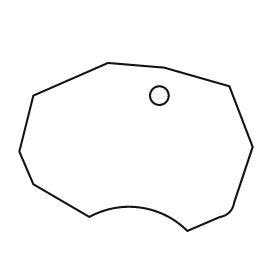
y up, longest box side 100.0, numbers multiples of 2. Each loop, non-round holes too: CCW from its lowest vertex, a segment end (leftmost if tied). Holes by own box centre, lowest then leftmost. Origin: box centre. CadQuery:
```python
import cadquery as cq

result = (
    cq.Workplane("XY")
    .moveTo(22.0, -36.0)
    .lineTo(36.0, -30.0)
    .threePointArc((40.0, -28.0), (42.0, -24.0))
    .lineTo(50.0, 0.0)
    .lineTo(40.0, 26.0)
    .lineTo(12.0, 34.0)
    .lineTo(-12.0, 36.0)
    .lineTo(-44.0, 22.0)
    .lineTo(-50.0, -2.0)
    .lineTo(-44.0, -16.0)
    .lineTo(-20.0, -30.0)
    .threePointArc((2.0, -26.0), (22.0, -36.0))
    .close()
    .moveTo(10.0, 22.0)
    .circle(4.0)
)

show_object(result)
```